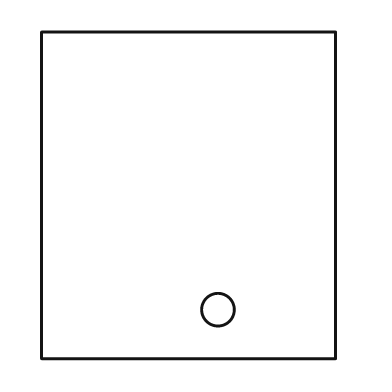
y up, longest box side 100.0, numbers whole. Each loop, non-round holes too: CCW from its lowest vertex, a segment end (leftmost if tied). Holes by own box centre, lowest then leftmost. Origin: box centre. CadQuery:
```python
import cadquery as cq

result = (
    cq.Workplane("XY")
    .moveTo(-45.0, -50.0)
    .lineTo(45.0, -50.0)
    .lineTo(45.0, 50.0)
    .lineTo(-45.0, 50.0)
    .close()
    .moveTo(9.0, -35.0)
    .circle(5.0)
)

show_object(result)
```